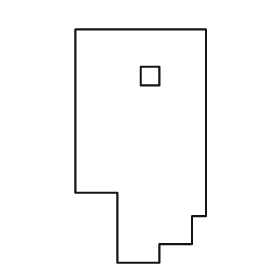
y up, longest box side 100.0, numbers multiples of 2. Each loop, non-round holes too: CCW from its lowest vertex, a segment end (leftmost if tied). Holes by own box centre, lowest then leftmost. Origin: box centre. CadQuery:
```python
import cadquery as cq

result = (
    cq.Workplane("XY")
    .moveTo(-10.0, -50.0)
    .lineTo(8.0, -50.0)
    .lineTo(8.0, -42.0)
    .lineTo(22.0, -42.0)
    .lineTo(22.0, -30.0)
    .lineTo(28.0, -30.0)
    .lineTo(28.0, 50.0)
    .lineTo(-28.0, 50.0)
    .lineTo(-28.0, -20.0)
    .lineTo(-10.0, -20.0)
    .close()
    .moveTo(0.0, 26.0)
    .lineTo(8.0, 26.0)
    .lineTo(8.0, 34.0)
    .lineTo(0.0, 34.0)
    .close()
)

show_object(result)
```